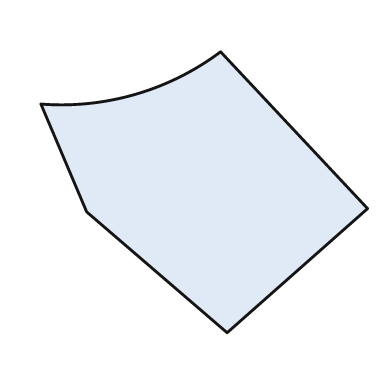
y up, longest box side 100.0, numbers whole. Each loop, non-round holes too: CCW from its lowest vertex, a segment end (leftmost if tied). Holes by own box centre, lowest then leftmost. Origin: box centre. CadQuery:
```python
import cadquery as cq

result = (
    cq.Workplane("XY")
    .moveTo(7.0, -43.0)
    .lineTo(50.0, -5.0)
    .lineTo(5.0, 43.0)
    .threePointArc((-21.0, 30.0), (-50.0, 27.0))
    .lineTo(-36.0, -6.0)
    .close()
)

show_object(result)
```